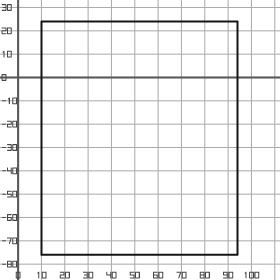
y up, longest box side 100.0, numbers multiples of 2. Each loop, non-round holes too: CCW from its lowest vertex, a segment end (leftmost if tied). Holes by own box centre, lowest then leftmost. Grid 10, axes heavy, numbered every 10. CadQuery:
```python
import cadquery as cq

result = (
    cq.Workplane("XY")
    .moveTo(10.0, -76.0)
    .lineTo(94.0, -76.0)
    .lineTo(94.0, 24.0)
    .lineTo(10.0, 24.0)
    .close()
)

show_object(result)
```